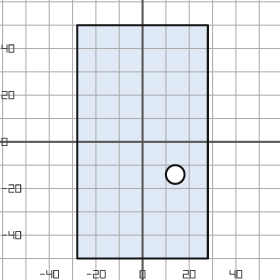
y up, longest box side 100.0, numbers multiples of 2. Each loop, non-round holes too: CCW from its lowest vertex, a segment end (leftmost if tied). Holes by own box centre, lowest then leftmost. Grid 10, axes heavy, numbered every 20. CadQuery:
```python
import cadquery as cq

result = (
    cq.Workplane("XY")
    .moveTo(-28.0, -50.0)
    .lineTo(28.0, -50.0)
    .lineTo(28.0, 50.0)
    .lineTo(-28.0, 50.0)
    .close()
    .moveTo(14.0, -14.0)
    .circle(4.0)
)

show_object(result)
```